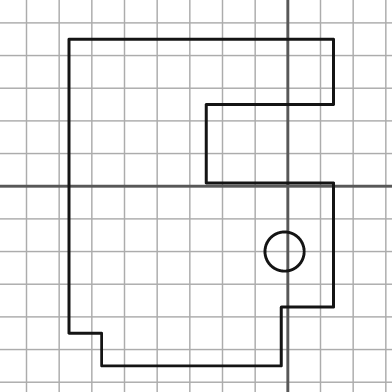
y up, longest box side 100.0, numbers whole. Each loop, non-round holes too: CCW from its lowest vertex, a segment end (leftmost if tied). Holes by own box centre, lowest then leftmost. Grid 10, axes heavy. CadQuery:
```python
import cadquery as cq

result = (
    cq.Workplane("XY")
    .moveTo(-57.0, -55.0)
    .lineTo(-2.0, -55.0)
    .lineTo(-2.0, -37.0)
    .lineTo(14.0, -37.0)
    .lineTo(14.0, 1.0)
    .lineTo(-25.0, 1.0)
    .lineTo(-25.0, 25.0)
    .lineTo(14.0, 25.0)
    .lineTo(14.0, 45.0)
    .lineTo(-67.0, 45.0)
    .lineTo(-67.0, -45.0)
    .lineTo(-57.0, -45.0)
    .close()
    .moveTo(-1.0, -20.0)
    .circle(6.0)
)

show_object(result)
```